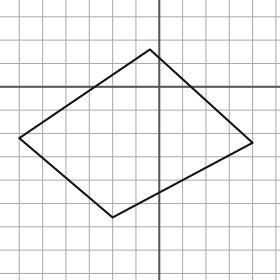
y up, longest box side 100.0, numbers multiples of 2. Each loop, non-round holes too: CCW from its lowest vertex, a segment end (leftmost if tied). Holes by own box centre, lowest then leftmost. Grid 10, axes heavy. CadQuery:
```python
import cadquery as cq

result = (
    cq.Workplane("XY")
    .moveTo(-20.0, -56.0)
    .lineTo(40.0, -24.0)
    .lineTo(-4.0, 16.0)
    .lineTo(-60.0, -22.0)
    .close()
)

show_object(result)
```